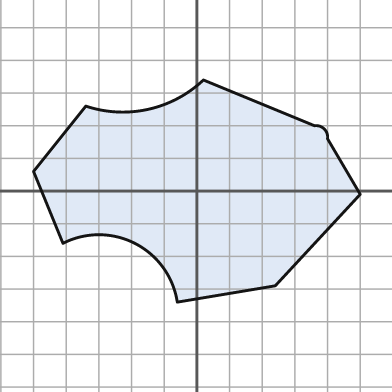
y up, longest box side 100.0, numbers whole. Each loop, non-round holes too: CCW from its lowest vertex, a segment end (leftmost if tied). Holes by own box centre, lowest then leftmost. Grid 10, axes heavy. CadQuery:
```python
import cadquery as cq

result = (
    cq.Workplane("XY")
    .moveTo(-6.0, -34.0)
    .lineTo(24.0, -29.0)
    .lineTo(50.0, -1.0)
    .lineTo(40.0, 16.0)
    .threePointArc((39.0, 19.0), (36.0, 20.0))
    .lineTo(2.0, 34.0)
    .threePointArc((-15.0, 25.0), (-34.0, 26.0))
    .lineTo(-50.0, 6.0)
    .lineTo(-41.0, -16.0)
    .threePointArc((-19.0, -16.0), (-6.0, -34.0))
    .close()
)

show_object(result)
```